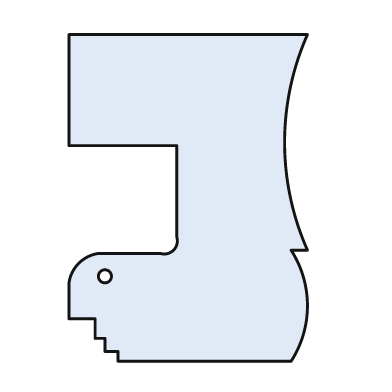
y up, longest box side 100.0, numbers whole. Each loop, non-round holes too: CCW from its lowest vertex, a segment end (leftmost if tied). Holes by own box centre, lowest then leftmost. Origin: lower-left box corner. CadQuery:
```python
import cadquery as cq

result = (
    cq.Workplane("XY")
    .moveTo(15.0, 0.0)
    .lineTo(68.0, 0.0)
    .threePointArc((73.0, 17.0), (68.0, 34.0))
    .lineTo(73.0, 34.0)
    .threePointArc((66.0, 67.0), (73.0, 100.0))
    .lineTo(0.0, 100.0)
    .lineTo(0.0, 66.0)
    .lineTo(33.0, 66.0)
    .lineTo(33.0, 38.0)
    .threePointArc((32.0, 34.0), (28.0, 33.0))
    .lineTo(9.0, 33.0)
    .threePointArc((3.0, 30.0), (0.0, 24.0))
    .lineTo(0.0, 13.0)
    .lineTo(8.0, 13.0)
    .lineTo(8.0, 7.0)
    .lineTo(11.0, 7.0)
    .lineTo(11.0, 3.0)
    .lineTo(15.0, 3.0)
    .close()
    .moveTo(11.0, 26.0)
    .circle(2.0)
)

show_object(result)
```